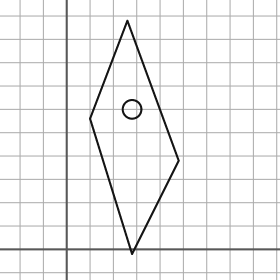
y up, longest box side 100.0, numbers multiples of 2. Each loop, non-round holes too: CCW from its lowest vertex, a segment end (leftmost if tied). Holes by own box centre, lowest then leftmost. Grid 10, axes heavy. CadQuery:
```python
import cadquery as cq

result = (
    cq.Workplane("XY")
    .moveTo(28.0, -2.0)
    .lineTo(48.0, 38.0)
    .lineTo(26.0, 98.0)
    .lineTo(10.0, 56.0)
    .close()
    .moveTo(28.0, 60.0)
    .circle(4.0)
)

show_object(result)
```